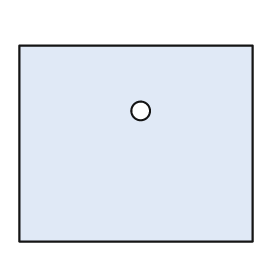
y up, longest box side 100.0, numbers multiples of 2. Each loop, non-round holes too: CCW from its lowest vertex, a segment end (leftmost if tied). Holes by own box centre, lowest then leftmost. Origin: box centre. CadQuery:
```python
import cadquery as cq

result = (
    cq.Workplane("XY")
    .moveTo(-50.0, -42.0)
    .lineTo(50.0, -42.0)
    .lineTo(50.0, 42.0)
    .lineTo(-50.0, 42.0)
    .close()
    .moveTo(2.0, 14.0)
    .circle(4.0)
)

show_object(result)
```